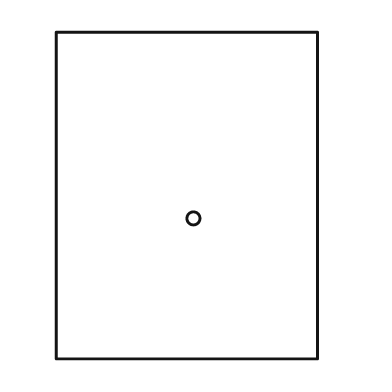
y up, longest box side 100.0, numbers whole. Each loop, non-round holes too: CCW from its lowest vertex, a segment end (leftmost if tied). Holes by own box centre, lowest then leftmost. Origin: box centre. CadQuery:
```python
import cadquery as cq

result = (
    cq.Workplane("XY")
    .moveTo(-40.0, -50.0)
    .lineTo(40.0, -50.0)
    .lineTo(40.0, 50.0)
    .lineTo(-40.0, 50.0)
    .close()
    .moveTo(2.0, -7.0)
    .circle(2.0)
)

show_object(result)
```